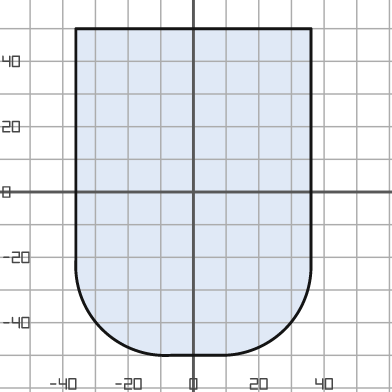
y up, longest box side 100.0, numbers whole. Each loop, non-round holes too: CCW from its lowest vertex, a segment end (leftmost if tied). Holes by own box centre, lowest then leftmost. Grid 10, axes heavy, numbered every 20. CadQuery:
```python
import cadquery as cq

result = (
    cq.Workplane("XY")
    .moveTo(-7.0, -50.0)
    .lineTo(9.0, -50.0)
    .threePointArc((28.0, -42.0), (36.0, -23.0))
    .lineTo(36.0, 50.0)
    .lineTo(-36.0, 50.0)
    .lineTo(-36.0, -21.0)
    .threePointArc((-28.0, -42.0), (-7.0, -50.0))
    .close()
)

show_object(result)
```